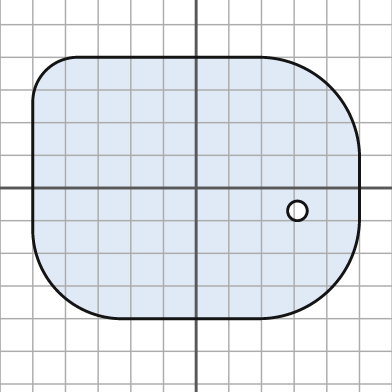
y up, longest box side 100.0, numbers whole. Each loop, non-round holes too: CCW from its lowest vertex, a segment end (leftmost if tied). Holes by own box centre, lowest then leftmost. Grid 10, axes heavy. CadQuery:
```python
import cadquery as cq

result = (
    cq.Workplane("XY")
    .moveTo(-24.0, -40.0)
    .lineTo(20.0, -40.0)
    .threePointArc((41.0, -31.0), (50.0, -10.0))
    .lineTo(50.0, 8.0)
    .threePointArc((41.0, 31.0), (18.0, 40.0))
    .lineTo(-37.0, 40.0)
    .threePointArc((-46.0, 36.0), (-50.0, 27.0))
    .lineTo(-50.0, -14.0)
    .threePointArc((-42.0, -32.0), (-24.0, -40.0))
    .close()
    .moveTo(31.0, -7.0)
    .circle(3.0)
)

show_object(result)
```